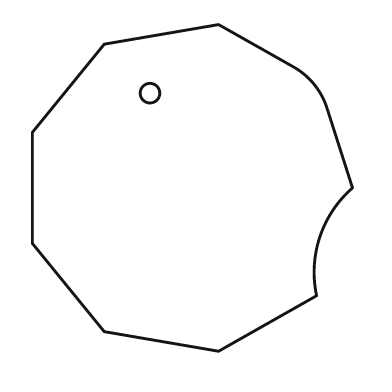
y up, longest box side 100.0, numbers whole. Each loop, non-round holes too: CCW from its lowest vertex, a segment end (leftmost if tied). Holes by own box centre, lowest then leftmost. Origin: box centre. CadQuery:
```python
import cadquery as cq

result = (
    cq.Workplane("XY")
    .moveTo(8.0, -50.0)
    .lineTo(38.0, -33.0)
    .threePointArc((39.0, -15.0), (49.0, 0.0))
    .lineTo(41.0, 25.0)
    .threePointArc((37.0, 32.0), (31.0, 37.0))
    .lineTo(8.0, 50.0)
    .lineTo(-27.0, 44.0)
    .lineTo(-49.0, 17.0)
    .lineTo(-49.0, -17.0)
    .lineTo(-27.0, -44.0)
    .close()
    .moveTo(-13.0, 29.0)
    .circle(3.0)
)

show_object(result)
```